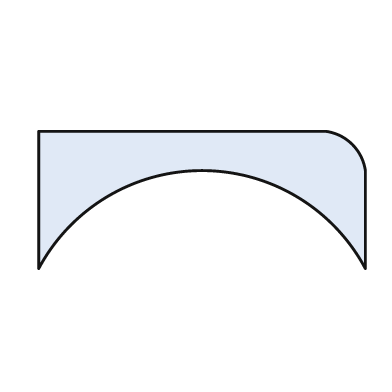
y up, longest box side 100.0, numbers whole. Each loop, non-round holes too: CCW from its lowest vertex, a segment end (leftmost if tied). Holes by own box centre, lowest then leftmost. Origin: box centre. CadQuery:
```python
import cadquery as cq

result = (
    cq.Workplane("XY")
    .moveTo(-50.0, -21.0)
    .threePointArc((0.0, 9.0), (50.0, -21.0))
    .lineTo(50.0, 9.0)
    .threePointArc((46.0, 17.0), (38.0, 21.0))
    .lineTo(-50.0, 21.0)
    .close()
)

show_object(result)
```